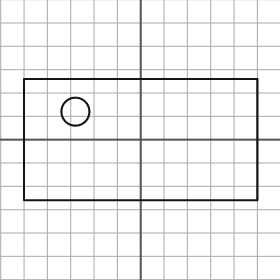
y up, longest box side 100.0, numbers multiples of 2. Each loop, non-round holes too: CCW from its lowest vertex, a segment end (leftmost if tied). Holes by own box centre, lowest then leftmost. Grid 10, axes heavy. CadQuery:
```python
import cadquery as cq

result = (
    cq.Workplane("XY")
    .moveTo(-50.0, -26.0)
    .lineTo(50.0, -26.0)
    .lineTo(50.0, 26.0)
    .lineTo(-50.0, 26.0)
    .close()
    .moveTo(-28.0, 12.0)
    .circle(6.0)
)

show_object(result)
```